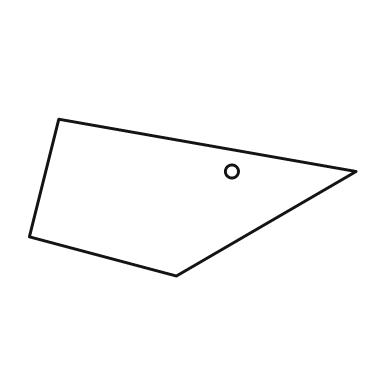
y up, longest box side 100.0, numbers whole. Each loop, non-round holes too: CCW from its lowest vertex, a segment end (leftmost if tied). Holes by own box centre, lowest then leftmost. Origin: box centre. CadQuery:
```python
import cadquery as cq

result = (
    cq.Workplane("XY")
    .moveTo(-5.0, -24.0)
    .lineTo(50.0, 8.0)
    .lineTo(-41.0, 24.0)
    .lineTo(-50.0, -12.0)
    .close()
    .moveTo(12.0, 8.0)
    .circle(2.0)
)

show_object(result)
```